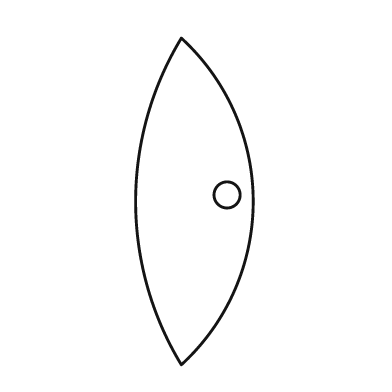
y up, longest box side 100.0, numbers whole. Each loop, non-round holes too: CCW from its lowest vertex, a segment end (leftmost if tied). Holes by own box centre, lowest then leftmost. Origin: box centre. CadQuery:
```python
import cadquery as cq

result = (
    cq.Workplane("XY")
    .moveTo(-4.0, -50.0)
    .threePointArc((18.0, 0.0), (-4.0, 50.0))
    .threePointArc((-18.0, 0.0), (-4.0, -50.0))
    .close()
    .moveTo(10.0, 2.0)
    .circle(4.0)
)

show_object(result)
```